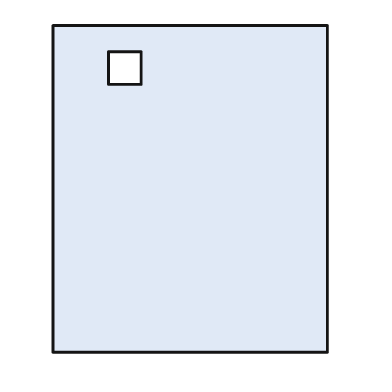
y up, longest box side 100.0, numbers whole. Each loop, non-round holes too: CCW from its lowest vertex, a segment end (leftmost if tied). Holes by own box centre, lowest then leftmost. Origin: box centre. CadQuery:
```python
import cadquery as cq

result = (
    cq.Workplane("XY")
    .moveTo(-42.0, -50.0)
    .lineTo(42.0, -50.0)
    .lineTo(42.0, 50.0)
    .lineTo(-42.0, 50.0)
    .close()
    .moveTo(-25.0, 32.0)
    .lineTo(-15.0, 32.0)
    .lineTo(-15.0, 42.0)
    .lineTo(-25.0, 42.0)
    .close()
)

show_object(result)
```